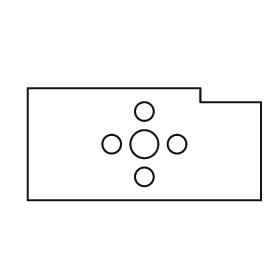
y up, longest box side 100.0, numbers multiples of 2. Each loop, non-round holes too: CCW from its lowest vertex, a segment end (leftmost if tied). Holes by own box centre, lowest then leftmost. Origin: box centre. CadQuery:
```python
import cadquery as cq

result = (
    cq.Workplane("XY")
    .moveTo(-50.0, -24.0)
    .lineTo(50.0, -24.0)
    .lineTo(50.0, 18.0)
    .lineTo(24.0, 18.0)
    .lineTo(24.0, 24.0)
    .lineTo(-50.0, 24.0)
    .close()
    .moveTo(0.0, -14.0)
    .circle(4.0)
    .moveTo(-14.0, 0.0)
    .circle(4.0)
    .moveTo(0.0, 0.0)
    .circle(6.0)
    .moveTo(14.0, 0.0)
    .circle(4.0)
    .moveTo(0.0, 14.0)
    .circle(4.0)
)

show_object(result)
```